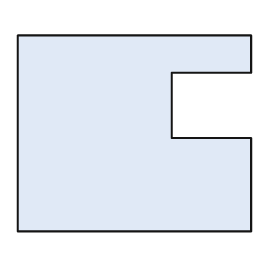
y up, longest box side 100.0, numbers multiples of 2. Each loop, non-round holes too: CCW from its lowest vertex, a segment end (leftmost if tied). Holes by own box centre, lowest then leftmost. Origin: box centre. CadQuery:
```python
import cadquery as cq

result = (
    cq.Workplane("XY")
    .moveTo(-50.0, -42.0)
    .lineTo(50.0, -42.0)
    .lineTo(50.0, -2.0)
    .lineTo(16.0, -2.0)
    .lineTo(16.0, 26.0)
    .lineTo(50.0, 26.0)
    .lineTo(50.0, 42.0)
    .lineTo(-50.0, 42.0)
    .close()
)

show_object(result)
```